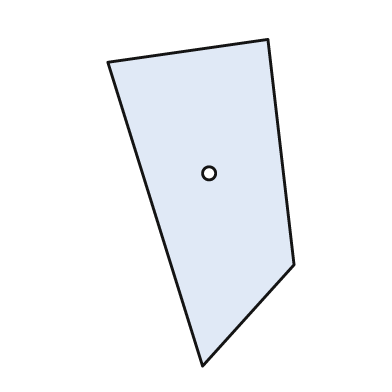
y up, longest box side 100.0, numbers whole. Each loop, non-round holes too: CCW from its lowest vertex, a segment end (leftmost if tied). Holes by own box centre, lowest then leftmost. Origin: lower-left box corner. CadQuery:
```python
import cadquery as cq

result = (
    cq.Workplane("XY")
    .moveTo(29.0, 0.0)
    .lineTo(57.0, 31.0)
    .lineTo(49.0, 100.0)
    .lineTo(0.0, 93.0)
    .close()
    .moveTo(31.0, 59.0)
    .circle(2.0)
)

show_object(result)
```